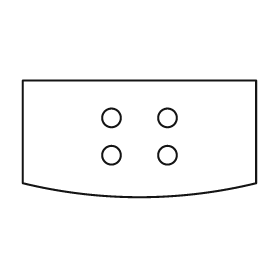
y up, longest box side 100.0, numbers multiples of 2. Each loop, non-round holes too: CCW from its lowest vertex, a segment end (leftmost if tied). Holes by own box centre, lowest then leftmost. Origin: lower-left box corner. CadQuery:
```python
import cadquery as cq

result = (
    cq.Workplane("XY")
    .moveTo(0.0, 6.0)
    .threePointArc((50.0, 0.0), (100.0, 6.0))
    .lineTo(100.0, 50.0)
    .lineTo(0.0, 50.0)
    .close()
    .moveTo(38.0, 18.0)
    .circle(4.0)
    .moveTo(62.0, 18.0)
    .circle(4.0)
    .moveTo(38.0, 34.0)
    .circle(4.0)
    .moveTo(62.0, 34.0)
    .circle(4.0)
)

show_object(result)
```